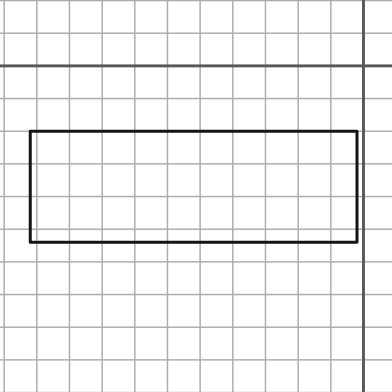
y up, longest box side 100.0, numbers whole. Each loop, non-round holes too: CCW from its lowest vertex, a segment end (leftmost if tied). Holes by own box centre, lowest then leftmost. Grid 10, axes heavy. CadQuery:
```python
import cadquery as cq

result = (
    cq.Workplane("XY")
    .moveTo(-102.0, -54.0)
    .lineTo(-2.0, -54.0)
    .lineTo(-2.0, -20.0)
    .lineTo(-102.0, -20.0)
    .close()
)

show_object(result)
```